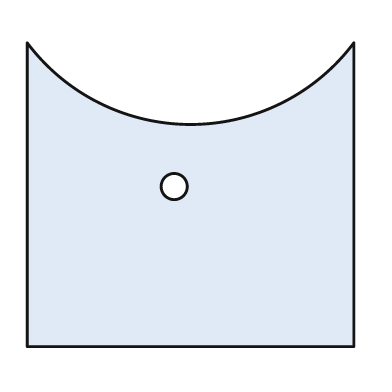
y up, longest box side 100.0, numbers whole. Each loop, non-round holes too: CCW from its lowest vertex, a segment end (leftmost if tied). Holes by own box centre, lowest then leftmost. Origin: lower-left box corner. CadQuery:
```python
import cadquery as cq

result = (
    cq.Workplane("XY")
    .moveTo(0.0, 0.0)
    .lineTo(100.0, 0.0)
    .lineTo(100.0, 93.0)
    .threePointArc((50.0, 68.0), (0.0, 93.0))
    .close()
    .moveTo(45.0, 49.0)
    .circle(4.0)
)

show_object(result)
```